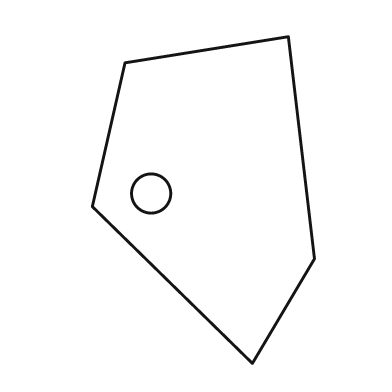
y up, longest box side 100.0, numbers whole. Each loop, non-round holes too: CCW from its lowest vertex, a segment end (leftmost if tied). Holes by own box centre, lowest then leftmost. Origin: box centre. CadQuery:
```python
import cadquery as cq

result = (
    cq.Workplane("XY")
    .moveTo(15.0, -50.0)
    .lineTo(34.0, -18.0)
    .lineTo(26.0, 50.0)
    .lineTo(-24.0, 42.0)
    .lineTo(-34.0, -2.0)
    .close()
    .moveTo(-16.0, 2.0)
    .circle(6.0)
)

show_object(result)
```